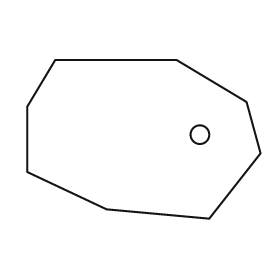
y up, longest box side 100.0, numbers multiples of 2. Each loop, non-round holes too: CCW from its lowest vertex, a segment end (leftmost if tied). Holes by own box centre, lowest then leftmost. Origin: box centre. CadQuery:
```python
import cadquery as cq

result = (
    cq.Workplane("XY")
    .moveTo(28.0, -34.0)
    .lineTo(50.0, -6.0)
    .lineTo(44.0, 16.0)
    .lineTo(14.0, 34.0)
    .lineTo(-38.0, 34.0)
    .lineTo(-50.0, 14.0)
    .lineTo(-50.0, -14.0)
    .lineTo(-16.0, -30.0)
    .close()
    .moveTo(24.0, 2.0)
    .circle(4.0)
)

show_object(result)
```